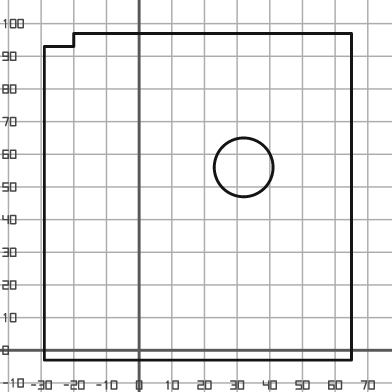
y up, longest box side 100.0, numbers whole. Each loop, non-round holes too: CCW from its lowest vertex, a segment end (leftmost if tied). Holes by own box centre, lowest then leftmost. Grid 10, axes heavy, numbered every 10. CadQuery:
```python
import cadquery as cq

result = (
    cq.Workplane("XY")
    .moveTo(-29.0, -3.0)
    .lineTo(65.0, -3.0)
    .lineTo(65.0, 97.0)
    .lineTo(-20.0, 97.0)
    .lineTo(-20.0, 93.0)
    .lineTo(-29.0, 93.0)
    .close()
    .moveTo(32.0, 56.0)
    .circle(9.0)
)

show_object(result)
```